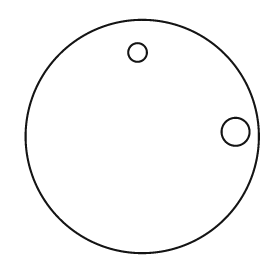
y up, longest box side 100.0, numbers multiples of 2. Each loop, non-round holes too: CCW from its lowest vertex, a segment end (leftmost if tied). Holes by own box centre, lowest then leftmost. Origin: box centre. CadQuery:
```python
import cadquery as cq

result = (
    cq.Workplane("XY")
    .moveTo(0.0, 0.0)
    .circle(50.0)
    .moveTo(40.0, 2.0)
    .circle(6.0)
    .moveTo(-2.0, 36.0)
    .circle(4.0)
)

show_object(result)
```